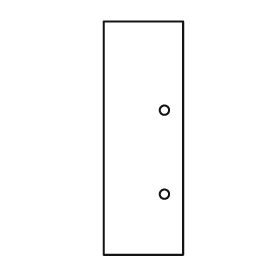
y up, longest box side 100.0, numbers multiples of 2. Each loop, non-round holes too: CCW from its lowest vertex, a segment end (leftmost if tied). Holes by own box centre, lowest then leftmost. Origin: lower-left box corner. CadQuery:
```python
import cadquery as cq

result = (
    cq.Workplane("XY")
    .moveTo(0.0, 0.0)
    .lineTo(34.0, 0.0)
    .lineTo(34.0, 100.0)
    .lineTo(0.0, 100.0)
    .close()
    .moveTo(26.0, 26.0)
    .circle(2.0)
    .moveTo(26.0, 62.0)
    .circle(2.0)
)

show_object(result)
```